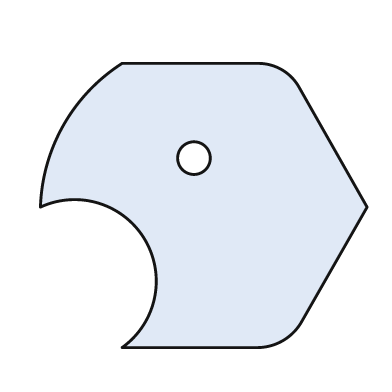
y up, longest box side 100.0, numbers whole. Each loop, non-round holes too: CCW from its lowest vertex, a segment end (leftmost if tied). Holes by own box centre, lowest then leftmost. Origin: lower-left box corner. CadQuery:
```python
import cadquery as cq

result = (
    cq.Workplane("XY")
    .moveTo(25.0, 0.0)
    .lineTo(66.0, 0.0)
    .threePointArc((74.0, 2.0), (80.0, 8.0))
    .lineTo(100.0, 43.0)
    .lineTo(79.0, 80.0)
    .threePointArc((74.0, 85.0), (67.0, 87.0))
    .lineTo(25.0, 87.0)
    .threePointArc((7.0, 68.0), (0.0, 43.0))
    .threePointArc((32.0, 33.0), (25.0, 0.0))
    .close()
    .moveTo(47.0, 58.0)
    .circle(5.0)
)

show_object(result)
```